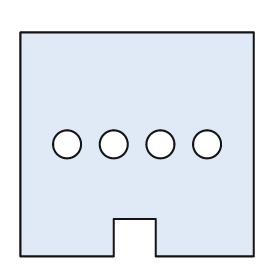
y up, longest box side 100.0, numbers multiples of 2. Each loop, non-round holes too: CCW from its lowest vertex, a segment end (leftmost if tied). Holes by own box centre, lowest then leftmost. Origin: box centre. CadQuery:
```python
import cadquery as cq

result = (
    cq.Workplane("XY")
    .moveTo(-50.0, -48.0)
    .lineTo(-10.0, -48.0)
    .lineTo(-10.0, -32.0)
    .lineTo(8.0, -32.0)
    .lineTo(8.0, -48.0)
    .lineTo(50.0, -48.0)
    .lineTo(50.0, 48.0)
    .lineTo(-50.0, 48.0)
    .close()
    .moveTo(-30.0, 0.0)
    .circle(6.0)
    .moveTo(-10.0, 0.0)
    .circle(6.0)
    .moveTo(10.0, 0.0)
    .circle(6.0)
    .moveTo(30.0, 0.0)
    .circle(6.0)
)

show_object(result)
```